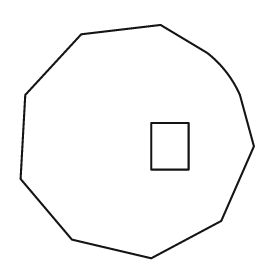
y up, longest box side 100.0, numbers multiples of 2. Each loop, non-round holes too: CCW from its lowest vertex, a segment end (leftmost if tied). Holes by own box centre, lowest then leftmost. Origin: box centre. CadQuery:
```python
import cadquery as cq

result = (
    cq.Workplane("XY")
    .moveTo(6.0, -50.0)
    .lineTo(36.0, -34.0)
    .lineTo(50.0, -2.0)
    .lineTo(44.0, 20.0)
    .threePointArc((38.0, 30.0), (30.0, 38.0))
    .lineTo(10.0, 50.0)
    .lineTo(-24.0, 46.0)
    .lineTo(-48.0, 20.0)
    .lineTo(-50.0, -16.0)
    .lineTo(-28.0, -42.0)
    .close()
    .moveTo(6.0, -12.0)
    .lineTo(22.0, -12.0)
    .lineTo(22.0, 8.0)
    .lineTo(6.0, 8.0)
    .close()
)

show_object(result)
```